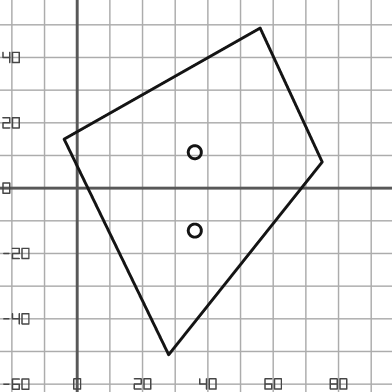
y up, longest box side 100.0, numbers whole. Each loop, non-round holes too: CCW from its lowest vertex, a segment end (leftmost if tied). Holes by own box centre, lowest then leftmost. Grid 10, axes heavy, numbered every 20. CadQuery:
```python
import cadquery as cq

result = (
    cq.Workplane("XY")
    .moveTo(28.0, -51.0)
    .lineTo(75.0, 8.0)
    .lineTo(56.0, 49.0)
    .lineTo(-4.0, 15.0)
    .close()
    .moveTo(36.0, -13.0)
    .circle(2.0)
    .moveTo(36.0, 11.0)
    .circle(2.0)
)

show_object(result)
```